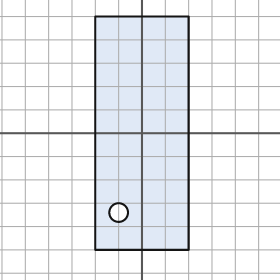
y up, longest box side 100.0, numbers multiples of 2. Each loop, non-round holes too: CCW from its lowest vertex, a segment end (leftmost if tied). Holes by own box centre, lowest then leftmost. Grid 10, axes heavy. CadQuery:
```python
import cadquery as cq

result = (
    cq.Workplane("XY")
    .moveTo(-20.0, -50.0)
    .lineTo(20.0, -50.0)
    .lineTo(20.0, 50.0)
    .lineTo(-20.0, 50.0)
    .close()
    .moveTo(-10.0, -34.0)
    .circle(4.0)
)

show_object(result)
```